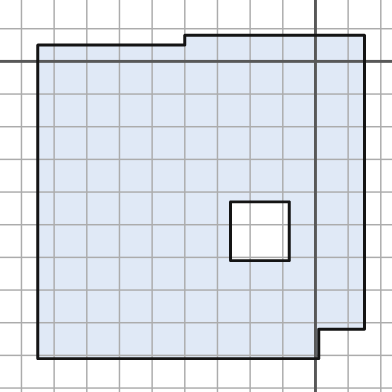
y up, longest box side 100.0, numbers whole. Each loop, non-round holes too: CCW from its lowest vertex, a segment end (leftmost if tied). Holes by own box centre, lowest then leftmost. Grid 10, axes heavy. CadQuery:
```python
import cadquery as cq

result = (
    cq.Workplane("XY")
    .moveTo(-85.0, -91.0)
    .lineTo(1.0, -91.0)
    .lineTo(1.0, -82.0)
    .lineTo(15.0, -82.0)
    .lineTo(15.0, 8.0)
    .lineTo(-40.0, 8.0)
    .lineTo(-40.0, 5.0)
    .lineTo(-85.0, 5.0)
    .close()
    .moveTo(-26.0, -61.0)
    .lineTo(-8.0, -61.0)
    .lineTo(-8.0, -43.0)
    .lineTo(-26.0, -43.0)
    .close()
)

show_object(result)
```